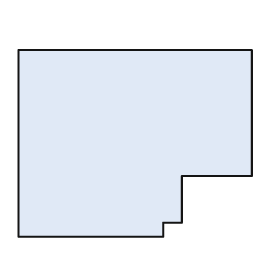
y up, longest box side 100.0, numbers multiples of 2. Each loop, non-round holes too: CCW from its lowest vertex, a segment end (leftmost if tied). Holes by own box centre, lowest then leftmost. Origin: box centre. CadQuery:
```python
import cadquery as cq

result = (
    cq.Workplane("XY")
    .moveTo(-50.0, -40.0)
    .lineTo(12.0, -40.0)
    .lineTo(12.0, -34.0)
    .lineTo(20.0, -34.0)
    .lineTo(20.0, -14.0)
    .lineTo(50.0, -14.0)
    .lineTo(50.0, 40.0)
    .lineTo(-50.0, 40.0)
    .close()
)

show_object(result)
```